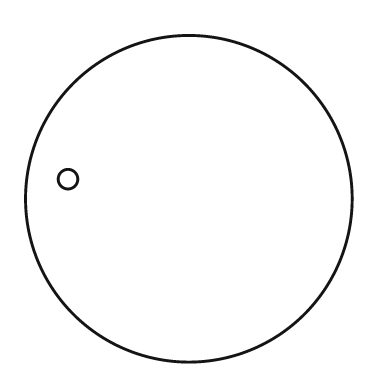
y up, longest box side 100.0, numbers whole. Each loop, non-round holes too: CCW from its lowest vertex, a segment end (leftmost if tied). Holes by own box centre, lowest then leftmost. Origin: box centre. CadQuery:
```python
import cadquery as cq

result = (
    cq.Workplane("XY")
    .moveTo(0.0, 0.0)
    .circle(50.0)
    .moveTo(-37.0, 6.0)
    .circle(3.0)
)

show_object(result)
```